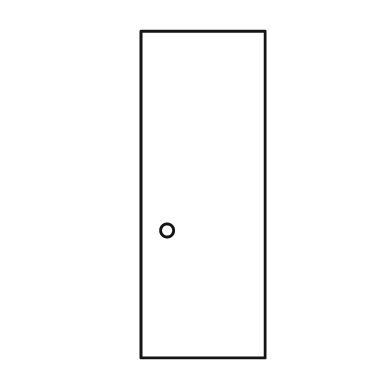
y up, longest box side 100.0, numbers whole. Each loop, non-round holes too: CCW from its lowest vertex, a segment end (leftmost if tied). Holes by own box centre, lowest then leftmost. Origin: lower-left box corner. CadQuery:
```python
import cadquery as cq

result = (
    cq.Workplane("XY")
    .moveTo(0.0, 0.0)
    .lineTo(38.0, 0.0)
    .lineTo(38.0, 100.0)
    .lineTo(0.0, 100.0)
    .close()
    .moveTo(8.0, 39.0)
    .circle(2.0)
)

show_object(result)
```